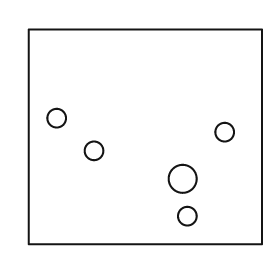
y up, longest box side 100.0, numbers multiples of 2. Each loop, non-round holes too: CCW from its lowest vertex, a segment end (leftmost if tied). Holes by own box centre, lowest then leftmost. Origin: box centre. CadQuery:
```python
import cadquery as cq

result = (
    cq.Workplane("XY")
    .moveTo(-50.0, -46.0)
    .lineTo(50.0, -46.0)
    .lineTo(50.0, 46.0)
    .lineTo(-50.0, 46.0)
    .close()
    .moveTo(18.0, -34.0)
    .circle(4.0)
    .moveTo(16.0, -18.0)
    .circle(6.0)
    .moveTo(-22.0, -6.0)
    .circle(4.0)
    .moveTo(34.0, 2.0)
    .circle(4.0)
    .moveTo(-38.0, 8.0)
    .circle(4.0)
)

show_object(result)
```